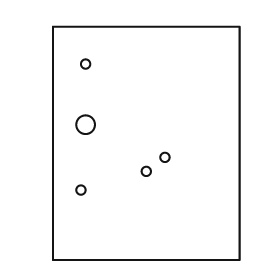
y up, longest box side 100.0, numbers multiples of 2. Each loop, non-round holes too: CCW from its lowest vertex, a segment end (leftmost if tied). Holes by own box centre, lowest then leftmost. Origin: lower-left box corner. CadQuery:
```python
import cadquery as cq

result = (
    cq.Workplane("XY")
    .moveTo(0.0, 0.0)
    .lineTo(80.0, 0.0)
    .lineTo(80.0, 100.0)
    .lineTo(0.0, 100.0)
    .close()
    .moveTo(12.0, 30.0)
    .circle(2.0)
    .moveTo(40.0, 38.0)
    .circle(2.0)
    .moveTo(48.0, 44.0)
    .circle(2.0)
    .moveTo(14.0, 58.0)
    .circle(4.0)
    .moveTo(14.0, 84.0)
    .circle(2.0)
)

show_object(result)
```